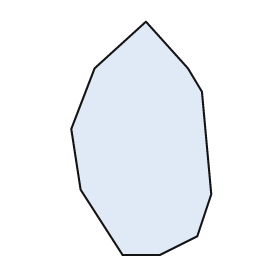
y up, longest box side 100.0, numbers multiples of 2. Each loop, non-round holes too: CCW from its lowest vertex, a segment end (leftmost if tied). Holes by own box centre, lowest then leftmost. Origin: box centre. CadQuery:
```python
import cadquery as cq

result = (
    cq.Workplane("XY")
    .moveTo(-8.0, -50.0)
    .lineTo(8.0, -50.0)
    .lineTo(24.0, -42.0)
    .lineTo(30.0, -24.0)
    .lineTo(26.0, 20.0)
    .lineTo(20.0, 30.0)
    .lineTo(2.0, 50.0)
    .lineTo(-20.0, 30.0)
    .lineTo(-30.0, 4.0)
    .lineTo(-26.0, -22.0)
    .close()
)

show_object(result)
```